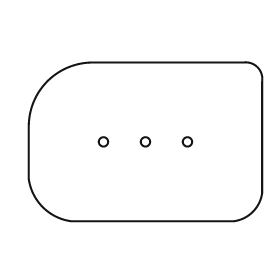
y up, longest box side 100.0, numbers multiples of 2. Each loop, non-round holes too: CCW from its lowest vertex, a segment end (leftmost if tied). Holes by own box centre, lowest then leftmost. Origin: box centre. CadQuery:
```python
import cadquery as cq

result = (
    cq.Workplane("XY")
    .moveTo(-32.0, -34.0)
    .lineTo(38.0, -34.0)
    .threePointArc((46.0, -30.0), (50.0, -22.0))
    .lineTo(50.0, 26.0)
    .threePointArc((48.0, 32.0), (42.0, 34.0))
    .lineTo(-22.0, 34.0)
    .threePointArc((-42.0, 26.0), (-50.0, 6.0))
    .lineTo(-50.0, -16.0)
    .threePointArc((-44.0, -28.0), (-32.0, -34.0))
    .close()
    .moveTo(-18.0, 0.0)
    .circle(2.0)
    .moveTo(0.0, 0.0)
    .circle(2.0)
    .moveTo(18.0, 0.0)
    .circle(2.0)
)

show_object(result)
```